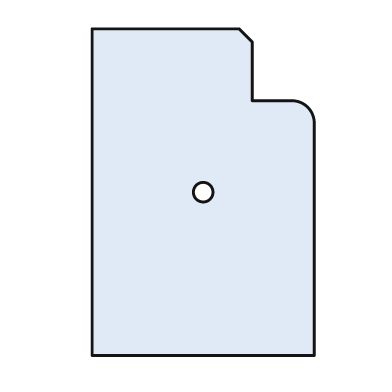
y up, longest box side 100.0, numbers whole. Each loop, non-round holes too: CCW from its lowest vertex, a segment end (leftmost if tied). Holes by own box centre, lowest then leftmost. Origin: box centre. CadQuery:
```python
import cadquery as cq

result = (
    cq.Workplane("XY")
    .moveTo(-34.0, -50.0)
    .lineTo(34.0, -50.0)
    .lineTo(34.0, 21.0)
    .threePointArc((32.0, 26.0), (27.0, 28.0))
    .lineTo(15.0, 28.0)
    .lineTo(15.0, 46.0)
    .lineTo(11.0, 50.0)
    .lineTo(-34.0, 50.0)
    .close()
    .moveTo(0.0, 0.0)
    .circle(3.0)
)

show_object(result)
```